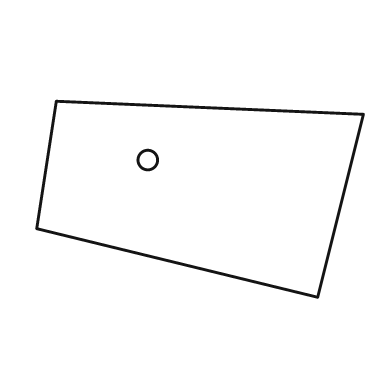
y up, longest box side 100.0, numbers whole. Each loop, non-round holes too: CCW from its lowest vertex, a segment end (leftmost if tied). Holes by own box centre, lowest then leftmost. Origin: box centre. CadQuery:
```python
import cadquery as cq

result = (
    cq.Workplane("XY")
    .moveTo(36.0, -30.0)
    .lineTo(50.0, 26.0)
    .lineTo(-44.0, 30.0)
    .lineTo(-50.0, -9.0)
    .close()
    .moveTo(-16.0, 12.0)
    .circle(3.0)
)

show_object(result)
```